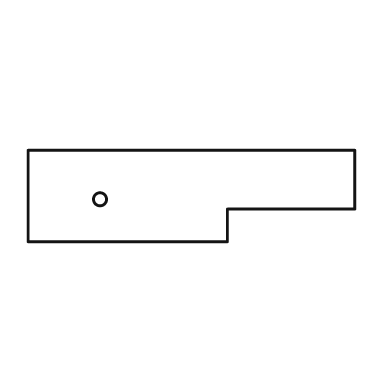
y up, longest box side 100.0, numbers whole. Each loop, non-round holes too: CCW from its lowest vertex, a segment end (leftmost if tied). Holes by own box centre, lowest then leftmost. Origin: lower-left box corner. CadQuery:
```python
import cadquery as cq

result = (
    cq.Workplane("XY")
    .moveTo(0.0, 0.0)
    .lineTo(61.0, 0.0)
    .lineTo(61.0, 10.0)
    .lineTo(100.0, 10.0)
    .lineTo(100.0, 28.0)
    .lineTo(0.0, 28.0)
    .close()
    .moveTo(22.0, 13.0)
    .circle(2.0)
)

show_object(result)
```